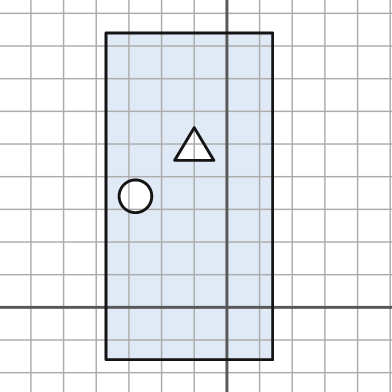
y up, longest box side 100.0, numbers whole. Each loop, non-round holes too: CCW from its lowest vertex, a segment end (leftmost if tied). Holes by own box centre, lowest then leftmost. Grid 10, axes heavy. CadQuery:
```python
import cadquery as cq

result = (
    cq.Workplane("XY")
    .moveTo(-37.0, -16.0)
    .lineTo(14.0, -16.0)
    .lineTo(14.0, 84.0)
    .lineTo(-37.0, 84.0)
    .close()
    .moveTo(-28.0, 34.0)
    .circle(5.0)
    .moveTo(-16.0, 45.0)
    .lineTo(-4.0, 45.0)
    .lineTo(-10.0, 55.0)
    .close()
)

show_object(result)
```